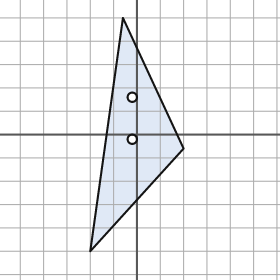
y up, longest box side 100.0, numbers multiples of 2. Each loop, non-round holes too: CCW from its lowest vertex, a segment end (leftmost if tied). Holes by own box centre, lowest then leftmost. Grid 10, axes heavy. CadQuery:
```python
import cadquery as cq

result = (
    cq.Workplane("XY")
    .moveTo(-20.0, -50.0)
    .lineTo(20.0, -6.0)
    .lineTo(-6.0, 50.0)
    .close()
    .moveTo(-2.0, -2.0)
    .circle(2.0)
    .moveTo(-2.0, 16.0)
    .circle(2.0)
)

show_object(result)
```